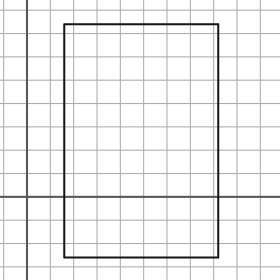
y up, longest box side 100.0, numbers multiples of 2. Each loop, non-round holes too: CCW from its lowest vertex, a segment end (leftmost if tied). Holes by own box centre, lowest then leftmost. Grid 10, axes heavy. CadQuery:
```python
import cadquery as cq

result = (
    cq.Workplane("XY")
    .moveTo(16.0, -26.0)
    .lineTo(82.0, -26.0)
    .lineTo(82.0, 74.0)
    .lineTo(16.0, 74.0)
    .close()
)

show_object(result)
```